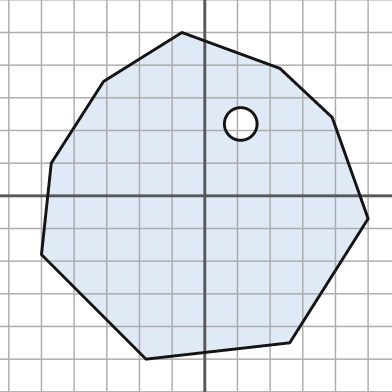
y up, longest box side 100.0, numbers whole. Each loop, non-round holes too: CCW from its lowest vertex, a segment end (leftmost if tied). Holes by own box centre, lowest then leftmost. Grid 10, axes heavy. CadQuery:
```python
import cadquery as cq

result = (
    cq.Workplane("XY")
    .moveTo(-18.0, -50.0)
    .lineTo(26.0, -45.0)
    .lineTo(50.0, -7.0)
    .lineTo(39.0, 24.0)
    .lineTo(23.0, 39.0)
    .lineTo(-7.0, 50.0)
    .lineTo(-31.0, 35.0)
    .lineTo(-47.0, 10.0)
    .lineTo(-50.0, -18.0)
    .close()
    .moveTo(11.0, 22.0)
    .circle(5.0)
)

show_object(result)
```